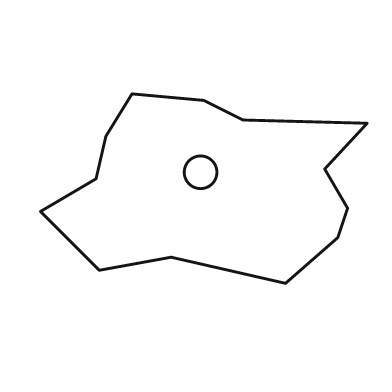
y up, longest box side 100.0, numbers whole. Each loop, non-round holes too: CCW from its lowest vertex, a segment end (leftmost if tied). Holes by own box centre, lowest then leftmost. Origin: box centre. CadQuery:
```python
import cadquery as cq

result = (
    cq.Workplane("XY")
    .moveTo(25.0, -29.0)
    .lineTo(41.0, -15.0)
    .lineTo(44.0, -6.0)
    .lineTo(37.0, 6.0)
    .lineTo(50.0, 20.0)
    .lineTo(12.0, 21.0)
    .lineTo(0.0, 27.0)
    .lineTo(-22.0, 29.0)
    .lineTo(-30.0, 16.0)
    .lineTo(-33.0, 3.0)
    .lineTo(-50.0, -7.0)
    .lineTo(-32.0, -25.0)
    .lineTo(-10.0, -21.0)
    .close()
    .moveTo(-1.0, 5.0)
    .circle(5.0)
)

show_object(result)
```